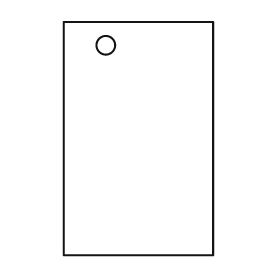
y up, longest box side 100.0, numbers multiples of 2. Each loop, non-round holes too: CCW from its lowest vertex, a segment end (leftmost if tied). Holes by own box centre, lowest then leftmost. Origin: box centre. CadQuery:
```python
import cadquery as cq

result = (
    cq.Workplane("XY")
    .moveTo(-32.0, -50.0)
    .lineTo(32.0, -50.0)
    .lineTo(32.0, 50.0)
    .lineTo(-32.0, 50.0)
    .close()
    .moveTo(-14.0, 40.0)
    .circle(4.0)
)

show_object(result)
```